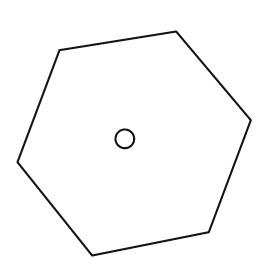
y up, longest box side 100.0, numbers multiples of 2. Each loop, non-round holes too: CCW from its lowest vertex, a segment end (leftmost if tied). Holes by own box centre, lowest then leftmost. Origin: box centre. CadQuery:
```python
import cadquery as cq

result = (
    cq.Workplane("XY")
    .moveTo(-18.0, -48.0)
    .lineTo(32.0, -38.0)
    .lineTo(50.0, 10.0)
    .lineTo(18.0, 48.0)
    .lineTo(-32.0, 40.0)
    .lineTo(-50.0, -8.0)
    .close()
    .moveTo(-4.0, 2.0)
    .circle(4.0)
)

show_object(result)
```